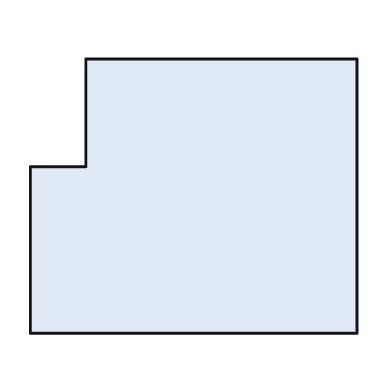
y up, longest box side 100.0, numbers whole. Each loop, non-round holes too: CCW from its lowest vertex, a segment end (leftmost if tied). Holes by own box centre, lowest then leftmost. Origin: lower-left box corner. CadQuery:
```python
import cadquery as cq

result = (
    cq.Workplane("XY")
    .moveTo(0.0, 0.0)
    .lineTo(100.0, 0.0)
    .lineTo(100.0, 84.0)
    .lineTo(17.0, 84.0)
    .lineTo(17.0, 51.0)
    .lineTo(0.0, 51.0)
    .close()
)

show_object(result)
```